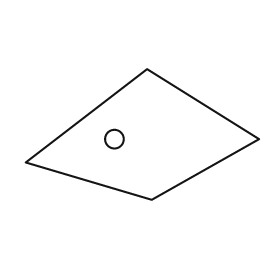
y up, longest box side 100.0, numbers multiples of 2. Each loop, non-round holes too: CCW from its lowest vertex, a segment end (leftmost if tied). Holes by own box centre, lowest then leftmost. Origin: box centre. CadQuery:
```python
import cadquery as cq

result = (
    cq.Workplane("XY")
    .moveTo(4.0, -28.0)
    .lineTo(50.0, -2.0)
    .lineTo(2.0, 28.0)
    .lineTo(-50.0, -12.0)
    .close()
    .moveTo(-12.0, -2.0)
    .circle(4.0)
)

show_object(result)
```